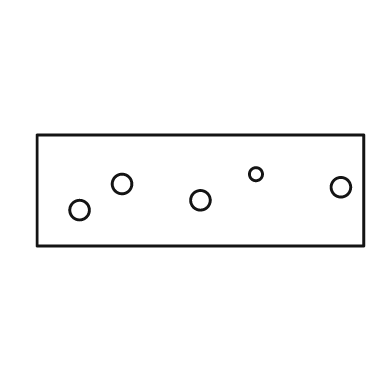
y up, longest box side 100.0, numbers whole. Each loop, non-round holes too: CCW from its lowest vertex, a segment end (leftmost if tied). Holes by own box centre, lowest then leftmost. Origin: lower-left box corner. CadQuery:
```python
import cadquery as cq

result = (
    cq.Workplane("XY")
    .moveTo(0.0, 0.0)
    .lineTo(100.0, 0.0)
    .lineTo(100.0, 34.0)
    .lineTo(0.0, 34.0)
    .close()
    .moveTo(13.0, 11.0)
    .circle(3.0)
    .moveTo(50.0, 14.0)
    .circle(3.0)
    .moveTo(93.0, 18.0)
    .circle(3.0)
    .moveTo(26.0, 19.0)
    .circle(3.0)
    .moveTo(67.0, 22.0)
    .circle(2.0)
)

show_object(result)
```